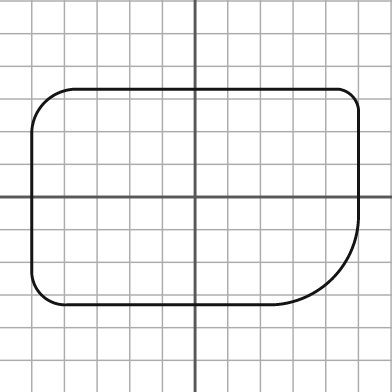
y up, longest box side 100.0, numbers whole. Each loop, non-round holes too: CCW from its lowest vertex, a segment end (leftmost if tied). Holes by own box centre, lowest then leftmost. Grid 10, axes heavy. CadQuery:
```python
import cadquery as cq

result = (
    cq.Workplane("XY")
    .moveTo(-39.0, -33.0)
    .lineTo(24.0, -33.0)
    .threePointArc((42.0, -25.0), (50.0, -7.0))
    .lineTo(50.0, 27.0)
    .threePointArc((48.0, 31.0), (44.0, 33.0))
    .lineTo(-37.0, 33.0)
    .threePointArc((-46.0, 29.0), (-50.0, 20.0))
    .lineTo(-50.0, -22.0)
    .threePointArc((-47.0, -30.0), (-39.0, -33.0))
    .close()
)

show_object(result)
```